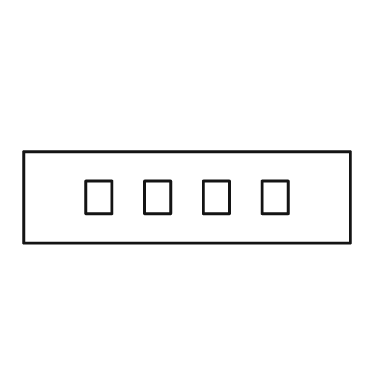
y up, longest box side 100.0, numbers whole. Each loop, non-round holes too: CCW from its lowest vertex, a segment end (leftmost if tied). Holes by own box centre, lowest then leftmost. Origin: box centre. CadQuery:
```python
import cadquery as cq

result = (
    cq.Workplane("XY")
    .moveTo(-50.0, -14.0)
    .lineTo(50.0, -14.0)
    .lineTo(50.0, 14.0)
    .lineTo(-50.0, 14.0)
    .close()
    .moveTo(-31.0, -5.0)
    .lineTo(-23.0, -5.0)
    .lineTo(-23.0, 5.0)
    .lineTo(-31.0, 5.0)
    .close()
    .moveTo(-13.0, -5.0)
    .lineTo(-5.0, -5.0)
    .lineTo(-5.0, 5.0)
    .lineTo(-13.0, 5.0)
    .close()
    .moveTo(5.0, -5.0)
    .lineTo(13.0, -5.0)
    .lineTo(13.0, 5.0)
    .lineTo(5.0, 5.0)
    .close()
    .moveTo(23.0, -5.0)
    .lineTo(31.0, -5.0)
    .lineTo(31.0, 5.0)
    .lineTo(23.0, 5.0)
    .close()
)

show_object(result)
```